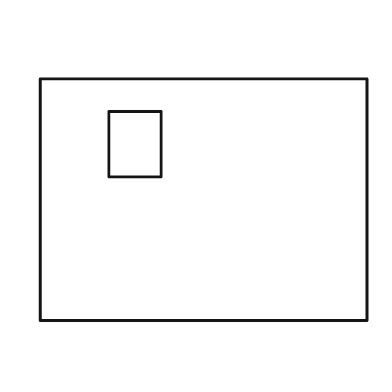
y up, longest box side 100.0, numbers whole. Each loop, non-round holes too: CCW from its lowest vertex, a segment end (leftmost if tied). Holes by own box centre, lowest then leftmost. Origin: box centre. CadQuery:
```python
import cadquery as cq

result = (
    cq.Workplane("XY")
    .moveTo(-50.0, -37.0)
    .lineTo(50.0, -37.0)
    .lineTo(50.0, 37.0)
    .lineTo(-50.0, 37.0)
    .close()
    .moveTo(-29.0, 7.0)
    .lineTo(-13.0, 7.0)
    .lineTo(-13.0, 27.0)
    .lineTo(-29.0, 27.0)
    .close()
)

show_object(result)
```